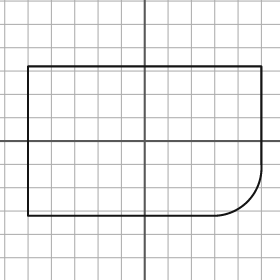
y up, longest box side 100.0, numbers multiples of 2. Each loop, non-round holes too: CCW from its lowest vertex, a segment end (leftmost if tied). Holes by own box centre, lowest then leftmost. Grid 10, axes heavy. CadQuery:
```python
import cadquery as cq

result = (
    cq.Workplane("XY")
    .moveTo(-50.0, -32.0)
    .lineTo(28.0, -32.0)
    .threePointArc((44.0, -26.0), (50.0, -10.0))
    .lineTo(50.0, 32.0)
    .lineTo(-50.0, 32.0)
    .close()
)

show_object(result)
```